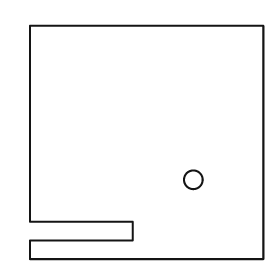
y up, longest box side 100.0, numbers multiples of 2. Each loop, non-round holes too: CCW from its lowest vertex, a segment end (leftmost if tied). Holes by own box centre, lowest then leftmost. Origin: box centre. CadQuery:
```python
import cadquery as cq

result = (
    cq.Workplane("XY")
    .moveTo(-50.0, -50.0)
    .lineTo(50.0, -50.0)
    .lineTo(50.0, 50.0)
    .lineTo(-50.0, 50.0)
    .lineTo(-50.0, -34.0)
    .lineTo(-6.0, -34.0)
    .lineTo(-6.0, -42.0)
    .lineTo(-50.0, -42.0)
    .close()
    .moveTo(20.0, -16.0)
    .circle(4.0)
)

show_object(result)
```